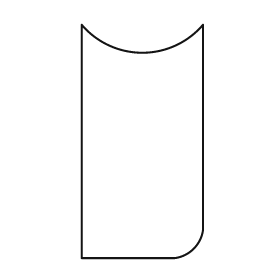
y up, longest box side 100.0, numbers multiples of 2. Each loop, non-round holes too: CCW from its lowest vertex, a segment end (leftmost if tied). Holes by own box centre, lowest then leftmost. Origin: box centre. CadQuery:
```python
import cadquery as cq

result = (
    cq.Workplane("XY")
    .moveTo(-26.0, -50.0)
    .lineTo(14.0, -50.0)
    .threePointArc((22.0, -46.0), (26.0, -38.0))
    .lineTo(26.0, 50.0)
    .threePointArc((0.0, 38.0), (-26.0, 50.0))
    .close()
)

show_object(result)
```